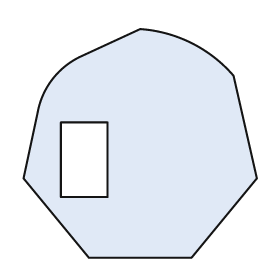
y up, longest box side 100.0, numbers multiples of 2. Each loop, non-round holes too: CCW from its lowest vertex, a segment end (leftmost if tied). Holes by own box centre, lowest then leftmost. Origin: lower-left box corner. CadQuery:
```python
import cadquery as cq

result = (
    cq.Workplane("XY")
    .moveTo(28.0, 0.0)
    .lineTo(72.0, 0.0)
    .lineTo(100.0, 34.0)
    .lineTo(90.0, 78.0)
    .threePointArc((72.0, 92.0), (50.0, 98.0))
    .lineTo(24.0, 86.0)
    .threePointArc((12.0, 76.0), (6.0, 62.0))
    .lineTo(0.0, 34.0)
    .close()
    .moveTo(16.0, 26.0)
    .lineTo(36.0, 26.0)
    .lineTo(36.0, 58.0)
    .lineTo(16.0, 58.0)
    .close()
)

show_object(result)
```